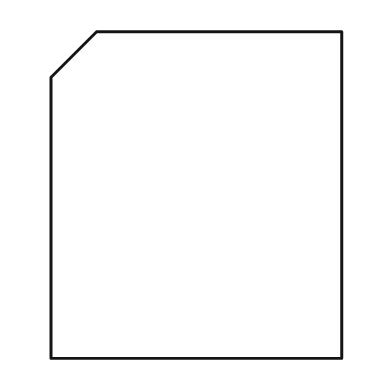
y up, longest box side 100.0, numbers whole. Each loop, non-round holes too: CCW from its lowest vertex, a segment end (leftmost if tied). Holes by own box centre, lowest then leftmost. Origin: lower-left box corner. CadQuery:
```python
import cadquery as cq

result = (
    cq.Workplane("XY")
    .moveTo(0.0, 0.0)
    .lineTo(89.0, 0.0)
    .lineTo(89.0, 100.0)
    .lineTo(14.0, 100.0)
    .lineTo(0.0, 86.0)
    .close()
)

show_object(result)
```